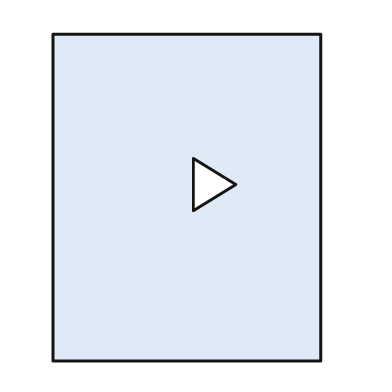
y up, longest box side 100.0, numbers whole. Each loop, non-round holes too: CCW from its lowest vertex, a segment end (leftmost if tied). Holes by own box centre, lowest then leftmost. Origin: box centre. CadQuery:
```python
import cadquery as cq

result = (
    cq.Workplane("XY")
    .moveTo(-41.0, -50.0)
    .lineTo(41.0, -50.0)
    .lineTo(41.0, 50.0)
    .lineTo(-41.0, 50.0)
    .close()
    .moveTo(2.0, -4.0)
    .lineTo(15.0, 4.0)
    .lineTo(2.0, 12.0)
    .close()
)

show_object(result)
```